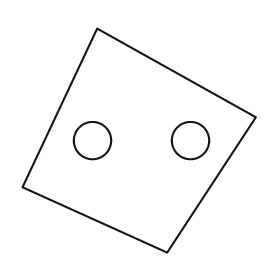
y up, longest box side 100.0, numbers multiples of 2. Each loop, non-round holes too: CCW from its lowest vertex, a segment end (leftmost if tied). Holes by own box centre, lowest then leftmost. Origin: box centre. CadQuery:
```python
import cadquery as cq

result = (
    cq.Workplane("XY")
    .moveTo(12.0, -48.0)
    .lineTo(50.0, 10.0)
    .lineTo(-18.0, 48.0)
    .lineTo(-50.0, -20.0)
    .close()
    .moveTo(-20.0, 0.0)
    .circle(8.0)
    .moveTo(22.0, 0.0)
    .circle(8.0)
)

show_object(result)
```